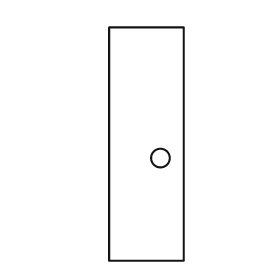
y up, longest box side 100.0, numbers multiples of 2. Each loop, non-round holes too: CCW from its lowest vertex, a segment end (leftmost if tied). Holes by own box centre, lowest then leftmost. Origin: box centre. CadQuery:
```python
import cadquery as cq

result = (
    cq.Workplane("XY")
    .moveTo(-16.0, -50.0)
    .lineTo(16.0, -50.0)
    .lineTo(16.0, 50.0)
    .lineTo(-16.0, 50.0)
    .close()
    .moveTo(6.0, -6.0)
    .circle(4.0)
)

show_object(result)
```